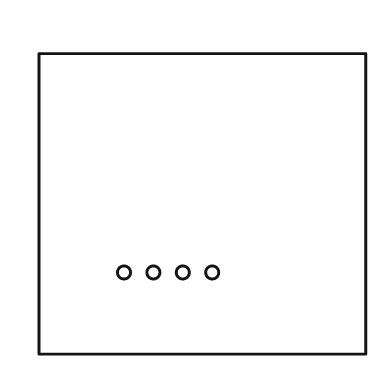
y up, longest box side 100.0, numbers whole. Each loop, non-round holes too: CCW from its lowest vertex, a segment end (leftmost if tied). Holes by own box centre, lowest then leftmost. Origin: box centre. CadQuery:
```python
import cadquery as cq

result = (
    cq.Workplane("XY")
    .moveTo(-50.0, -46.0)
    .lineTo(50.0, -46.0)
    .lineTo(50.0, 46.0)
    .lineTo(-50.0, 46.0)
    .close()
    .moveTo(-24.0, -21.0)
    .circle(2.0)
    .moveTo(-15.0, -21.0)
    .circle(2.0)
    .moveTo(-6.0, -21.0)
    .circle(2.0)
    .moveTo(3.0, -21.0)
    .circle(2.0)
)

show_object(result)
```